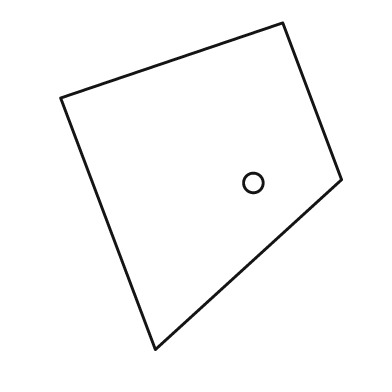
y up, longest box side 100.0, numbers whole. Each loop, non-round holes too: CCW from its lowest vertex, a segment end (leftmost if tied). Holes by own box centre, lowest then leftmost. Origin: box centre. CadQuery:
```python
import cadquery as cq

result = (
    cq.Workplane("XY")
    .moveTo(-14.0, -50.0)
    .lineTo(43.0, 2.0)
    .lineTo(25.0, 50.0)
    .lineTo(-43.0, 27.0)
    .close()
    .moveTo(16.0, 1.0)
    .circle(3.0)
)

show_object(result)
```